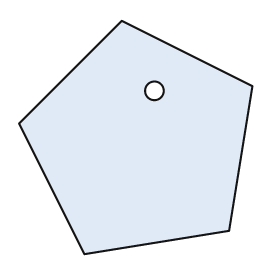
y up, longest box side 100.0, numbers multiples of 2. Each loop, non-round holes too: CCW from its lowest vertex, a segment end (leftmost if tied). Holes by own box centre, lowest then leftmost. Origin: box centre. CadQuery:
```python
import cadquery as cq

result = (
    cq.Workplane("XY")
    .moveTo(-22.0, -50.0)
    .lineTo(40.0, -40.0)
    .lineTo(50.0, 22.0)
    .lineTo(-6.0, 50.0)
    .lineTo(-50.0, 6.0)
    .close()
    .moveTo(8.0, 20.0)
    .circle(4.0)
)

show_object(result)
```